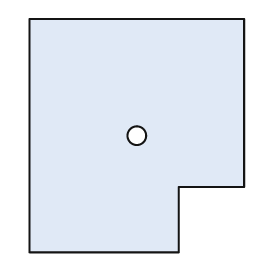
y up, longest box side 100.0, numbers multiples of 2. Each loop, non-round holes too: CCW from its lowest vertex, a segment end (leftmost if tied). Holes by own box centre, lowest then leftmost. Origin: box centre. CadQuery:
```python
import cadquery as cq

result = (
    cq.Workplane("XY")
    .moveTo(-46.0, -50.0)
    .lineTo(18.0, -50.0)
    .lineTo(18.0, -22.0)
    .lineTo(46.0, -22.0)
    .lineTo(46.0, 50.0)
    .lineTo(-46.0, 50.0)
    .close()
    .moveTo(0.0, 0.0)
    .circle(4.0)
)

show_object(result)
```